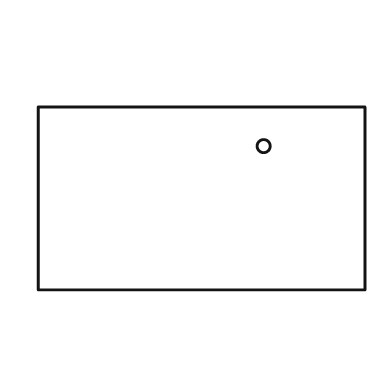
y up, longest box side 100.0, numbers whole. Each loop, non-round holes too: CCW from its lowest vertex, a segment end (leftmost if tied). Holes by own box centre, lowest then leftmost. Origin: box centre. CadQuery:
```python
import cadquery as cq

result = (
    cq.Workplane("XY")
    .moveTo(-50.0, -28.0)
    .lineTo(50.0, -28.0)
    .lineTo(50.0, 28.0)
    .lineTo(-50.0, 28.0)
    .close()
    .moveTo(19.0, 16.0)
    .circle(2.0)
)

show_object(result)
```